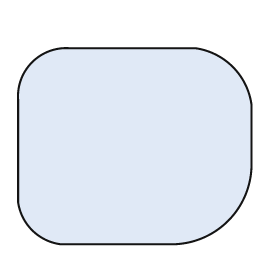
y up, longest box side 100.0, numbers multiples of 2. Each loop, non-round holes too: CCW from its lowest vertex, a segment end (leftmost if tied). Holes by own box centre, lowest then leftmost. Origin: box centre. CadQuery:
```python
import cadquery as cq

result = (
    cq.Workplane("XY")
    .moveTo(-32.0, -42.0)
    .lineTo(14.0, -42.0)
    .threePointArc((40.0, -32.0), (50.0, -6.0))
    .lineTo(50.0, 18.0)
    .threePointArc((42.0, 34.0), (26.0, 42.0))
    .lineTo(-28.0, 42.0)
    .threePointArc((-44.0, 36.0), (-50.0, 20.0))
    .lineTo(-50.0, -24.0)
    .threePointArc((-44.0, -36.0), (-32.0, -42.0))
    .close()
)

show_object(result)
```